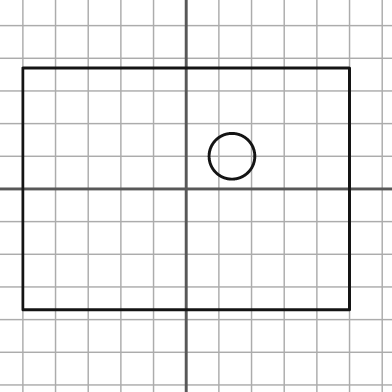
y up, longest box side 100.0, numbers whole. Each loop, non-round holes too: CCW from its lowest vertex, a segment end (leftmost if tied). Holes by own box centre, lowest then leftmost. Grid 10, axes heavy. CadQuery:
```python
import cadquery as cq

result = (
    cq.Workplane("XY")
    .moveTo(-50.0, -37.0)
    .lineTo(50.0, -37.0)
    .lineTo(50.0, 37.0)
    .lineTo(-50.0, 37.0)
    .close()
    .moveTo(14.0, 10.0)
    .circle(7.0)
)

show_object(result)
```